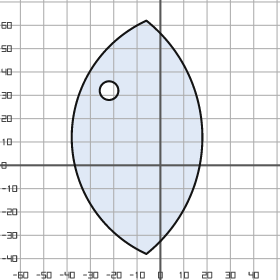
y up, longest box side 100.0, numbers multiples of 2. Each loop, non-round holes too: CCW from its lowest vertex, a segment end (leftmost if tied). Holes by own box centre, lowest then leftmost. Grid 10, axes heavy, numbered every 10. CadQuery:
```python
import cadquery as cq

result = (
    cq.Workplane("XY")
    .moveTo(-6.0, -38.0)
    .threePointArc((18.0, 12.0), (-6.0, 62.0))
    .threePointArc((-38.0, 12.0), (-6.0, -38.0))
    .close()
    .moveTo(-22.0, 32.0)
    .circle(4.0)
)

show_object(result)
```